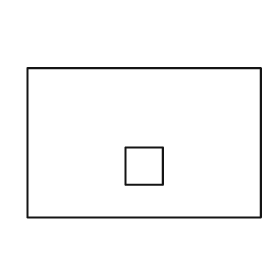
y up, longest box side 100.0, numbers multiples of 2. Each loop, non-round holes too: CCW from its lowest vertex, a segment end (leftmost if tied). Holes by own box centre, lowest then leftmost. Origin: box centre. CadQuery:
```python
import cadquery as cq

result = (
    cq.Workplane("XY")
    .moveTo(-50.0, -32.0)
    .lineTo(50.0, -32.0)
    .lineTo(50.0, 32.0)
    .lineTo(-50.0, 32.0)
    .close()
    .moveTo(-8.0, -18.0)
    .lineTo(8.0, -18.0)
    .lineTo(8.0, -2.0)
    .lineTo(-8.0, -2.0)
    .close()
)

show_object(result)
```